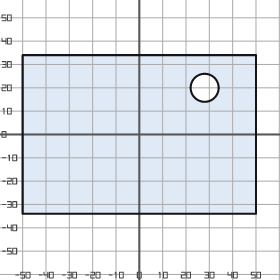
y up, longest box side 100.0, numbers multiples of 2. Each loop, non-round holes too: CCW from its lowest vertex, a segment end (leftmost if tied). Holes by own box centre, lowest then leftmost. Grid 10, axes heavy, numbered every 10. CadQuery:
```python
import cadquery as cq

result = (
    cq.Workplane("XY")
    .moveTo(-50.0, -34.0)
    .lineTo(50.0, -34.0)
    .lineTo(50.0, 34.0)
    .lineTo(-50.0, 34.0)
    .close()
    .moveTo(28.0, 20.0)
    .circle(6.0)
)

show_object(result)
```